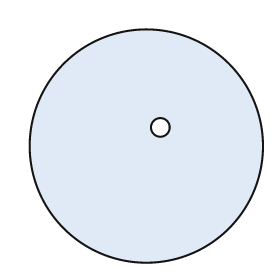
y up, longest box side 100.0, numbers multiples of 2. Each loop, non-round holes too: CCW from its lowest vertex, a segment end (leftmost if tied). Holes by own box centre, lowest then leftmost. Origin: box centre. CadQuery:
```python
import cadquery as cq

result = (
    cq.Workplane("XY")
    .moveTo(0.0, 0.0)
    .circle(50.0)
    .moveTo(6.0, 8.0)
    .circle(4.0)
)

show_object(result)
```